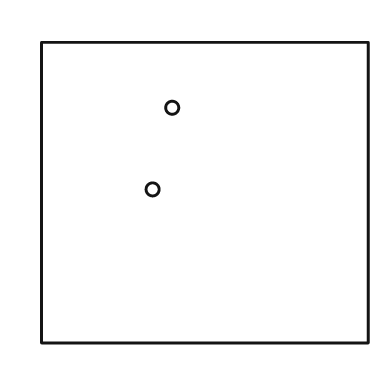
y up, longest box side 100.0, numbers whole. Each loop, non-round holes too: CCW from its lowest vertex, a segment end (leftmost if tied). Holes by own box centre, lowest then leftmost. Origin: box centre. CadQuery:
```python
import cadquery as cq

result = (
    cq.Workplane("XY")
    .moveTo(-50.0, -46.0)
    .lineTo(50.0, -46.0)
    .lineTo(50.0, 46.0)
    .lineTo(-50.0, 46.0)
    .close()
    .moveTo(-16.0, 1.0)
    .circle(2.0)
    .moveTo(-10.0, 26.0)
    .circle(2.0)
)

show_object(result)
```